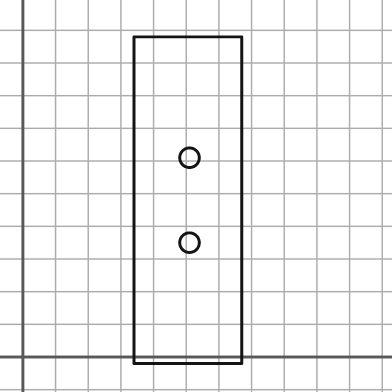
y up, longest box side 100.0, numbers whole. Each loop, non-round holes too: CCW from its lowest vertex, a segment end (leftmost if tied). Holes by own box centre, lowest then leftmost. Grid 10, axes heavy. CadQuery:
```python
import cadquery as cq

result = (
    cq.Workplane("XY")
    .moveTo(34.0, -2.0)
    .lineTo(67.0, -2.0)
    .lineTo(67.0, 98.0)
    .lineTo(34.0, 98.0)
    .close()
    .moveTo(51.0, 35.0)
    .circle(3.0)
    .moveTo(51.0, 61.0)
    .circle(3.0)
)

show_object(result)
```